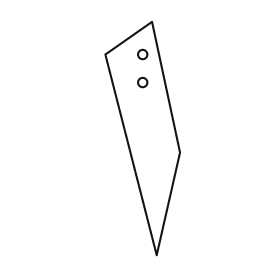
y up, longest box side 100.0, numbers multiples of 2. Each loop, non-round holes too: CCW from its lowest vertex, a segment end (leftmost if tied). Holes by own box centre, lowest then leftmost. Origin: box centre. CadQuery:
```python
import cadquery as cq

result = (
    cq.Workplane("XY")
    .moveTo(6.0, -50.0)
    .lineTo(16.0, -6.0)
    .lineTo(4.0, 50.0)
    .lineTo(-16.0, 36.0)
    .close()
    .moveTo(0.0, 24.0)
    .circle(2.0)
    .moveTo(0.0, 36.0)
    .circle(2.0)
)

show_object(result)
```